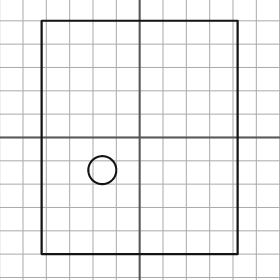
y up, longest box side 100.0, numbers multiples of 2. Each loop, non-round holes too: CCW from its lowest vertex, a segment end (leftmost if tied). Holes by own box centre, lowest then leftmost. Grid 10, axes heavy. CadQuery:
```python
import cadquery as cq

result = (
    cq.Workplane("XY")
    .moveTo(-42.0, -50.0)
    .lineTo(42.0, -50.0)
    .lineTo(42.0, 50.0)
    .lineTo(-42.0, 50.0)
    .close()
    .moveTo(-16.0, -14.0)
    .circle(6.0)
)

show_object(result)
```